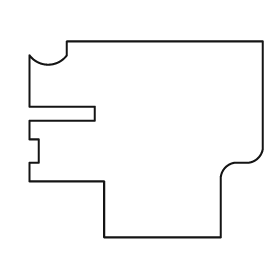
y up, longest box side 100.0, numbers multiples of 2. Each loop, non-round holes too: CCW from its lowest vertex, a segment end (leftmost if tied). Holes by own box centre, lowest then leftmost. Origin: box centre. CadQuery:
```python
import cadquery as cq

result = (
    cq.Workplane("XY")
    .moveTo(-18.0, -42.0)
    .lineTo(32.0, -42.0)
    .lineTo(32.0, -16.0)
    .threePointArc((34.0, -12.0), (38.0, -10.0))
    .lineTo(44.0, -10.0)
    .threePointArc((48.0, -8.0), (50.0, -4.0))
    .lineTo(50.0, 42.0)
    .lineTo(-34.0, 42.0)
    .lineTo(-34.0, 36.0)
    .threePointArc((-42.0, 32.0), (-50.0, 36.0))
    .lineTo(-50.0, 14.0)
    .lineTo(-22.0, 14.0)
    .lineTo(-22.0, 8.0)
    .lineTo(-50.0, 8.0)
    .lineTo(-50.0, 0.0)
    .lineTo(-46.0, 0.0)
    .lineTo(-46.0, -10.0)
    .lineTo(-50.0, -10.0)
    .lineTo(-50.0, -18.0)
    .lineTo(-18.0, -18.0)
    .close()
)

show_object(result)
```